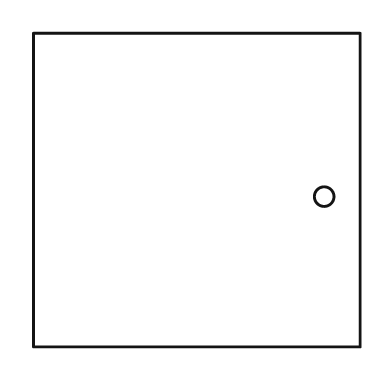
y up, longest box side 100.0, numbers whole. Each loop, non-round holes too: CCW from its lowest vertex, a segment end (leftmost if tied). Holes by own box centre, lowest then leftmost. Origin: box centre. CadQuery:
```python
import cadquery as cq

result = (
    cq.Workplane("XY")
    .moveTo(-50.0, -48.0)
    .lineTo(50.0, -48.0)
    .lineTo(50.0, 48.0)
    .lineTo(-50.0, 48.0)
    .close()
    .moveTo(39.0, -2.0)
    .circle(3.0)
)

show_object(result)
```